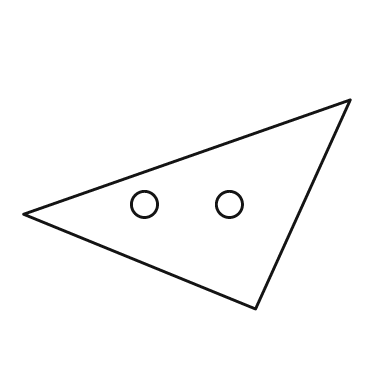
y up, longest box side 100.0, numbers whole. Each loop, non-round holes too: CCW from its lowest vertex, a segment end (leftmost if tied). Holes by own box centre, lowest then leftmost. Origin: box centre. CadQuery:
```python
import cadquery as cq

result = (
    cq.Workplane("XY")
    .moveTo(21.0, -32.0)
    .lineTo(50.0, 32.0)
    .lineTo(-50.0, -3.0)
    .close()
    .moveTo(-13.0, 0.0)
    .circle(4.0)
    .moveTo(13.0, 0.0)
    .circle(4.0)
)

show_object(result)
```